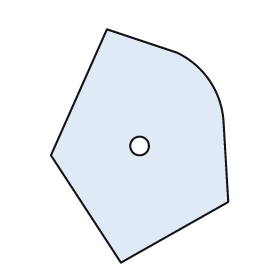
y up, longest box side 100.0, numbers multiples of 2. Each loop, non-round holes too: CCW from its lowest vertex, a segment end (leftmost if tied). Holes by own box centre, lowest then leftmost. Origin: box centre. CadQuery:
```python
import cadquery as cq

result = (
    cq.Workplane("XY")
    .moveTo(-8.0, -50.0)
    .lineTo(38.0, -24.0)
    .lineTo(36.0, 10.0)
    .threePointArc((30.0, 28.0), (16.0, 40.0))
    .lineTo(-14.0, 50.0)
    .lineTo(-38.0, -4.0)
    .close()
    .moveTo(0.0, 0.0)
    .circle(4.0)
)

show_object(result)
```